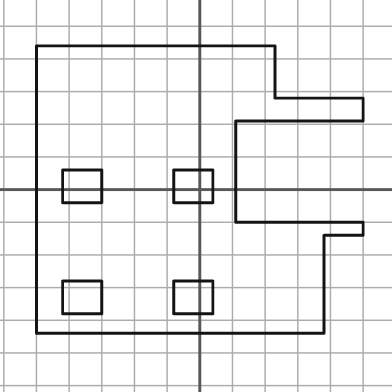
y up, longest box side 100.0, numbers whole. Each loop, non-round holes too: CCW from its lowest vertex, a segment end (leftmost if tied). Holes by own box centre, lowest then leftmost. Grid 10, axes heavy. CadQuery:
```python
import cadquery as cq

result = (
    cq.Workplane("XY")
    .moveTo(-50.0, -44.0)
    .lineTo(38.0, -44.0)
    .lineTo(38.0, -14.0)
    .lineTo(50.0, -14.0)
    .lineTo(50.0, -10.0)
    .lineTo(11.0, -10.0)
    .lineTo(11.0, 21.0)
    .lineTo(50.0, 21.0)
    .lineTo(50.0, 28.0)
    .lineTo(23.0, 28.0)
    .lineTo(23.0, 44.0)
    .lineTo(-50.0, 44.0)
    .close()
    .moveTo(-42.0, -38.0)
    .lineTo(-30.0, -38.0)
    .lineTo(-30.0, -28.0)
    .lineTo(-42.0, -28.0)
    .close()
    .moveTo(-8.0, -38.0)
    .lineTo(4.0, -38.0)
    .lineTo(4.0, -28.0)
    .lineTo(-8.0, -28.0)
    .close()
    .moveTo(-42.0, -4.0)
    .lineTo(-30.0, -4.0)
    .lineTo(-30.0, 6.0)
    .lineTo(-42.0, 6.0)
    .close()
    .moveTo(-8.0, -4.0)
    .lineTo(4.0, -4.0)
    .lineTo(4.0, 6.0)
    .lineTo(-8.0, 6.0)
    .close()
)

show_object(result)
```